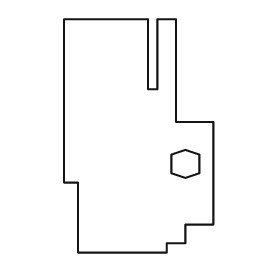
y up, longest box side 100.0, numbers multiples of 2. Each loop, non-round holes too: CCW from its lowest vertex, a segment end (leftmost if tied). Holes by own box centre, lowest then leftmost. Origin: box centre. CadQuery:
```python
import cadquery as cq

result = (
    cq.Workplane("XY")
    .moveTo(-26.0, -50.0)
    .lineTo(12.0, -50.0)
    .lineTo(12.0, -46.0)
    .lineTo(20.0, -46.0)
    .lineTo(20.0, -38.0)
    .lineTo(32.0, -38.0)
    .lineTo(32.0, 6.0)
    .lineTo(16.0, 6.0)
    .lineTo(16.0, 50.0)
    .lineTo(8.0, 50.0)
    .lineTo(8.0, 20.0)
    .lineTo(4.0, 20.0)
    .lineTo(4.0, 50.0)
    .lineTo(-32.0, 50.0)
    .lineTo(-32.0, -20.0)
    .lineTo(-26.0, -20.0)
    .close()
    .moveTo(20.0, -18.0)
    .lineTo(26.0, -16.0)
    .lineTo(26.0, -8.0)
    .lineTo(20.0, -6.0)
    .lineTo(14.0, -8.0)
    .lineTo(14.0, -16.0)
    .close()
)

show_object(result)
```